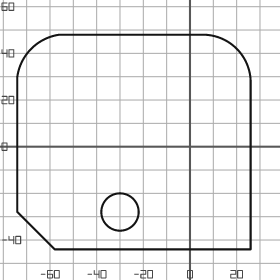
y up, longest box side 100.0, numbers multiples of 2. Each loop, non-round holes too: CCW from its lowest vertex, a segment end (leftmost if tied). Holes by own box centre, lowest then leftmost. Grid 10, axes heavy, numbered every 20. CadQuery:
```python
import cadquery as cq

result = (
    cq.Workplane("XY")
    .moveTo(-58.0, -44.0)
    .lineTo(26.0, -44.0)
    .lineTo(26.0, 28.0)
    .threePointArc((20.0, 42.0), (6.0, 48.0))
    .lineTo(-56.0, 48.0)
    .threePointArc((-68.0, 42.0), (-74.0, 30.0))
    .lineTo(-74.0, -28.0)
    .close()
    .moveTo(-30.0, -28.0)
    .circle(8.0)
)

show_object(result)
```